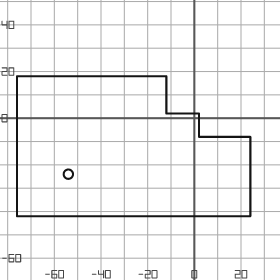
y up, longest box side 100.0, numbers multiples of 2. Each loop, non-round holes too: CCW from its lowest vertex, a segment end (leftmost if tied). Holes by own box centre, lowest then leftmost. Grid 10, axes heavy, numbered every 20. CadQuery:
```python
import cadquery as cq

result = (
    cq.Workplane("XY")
    .moveTo(-76.0, -42.0)
    .lineTo(24.0, -42.0)
    .lineTo(24.0, -8.0)
    .lineTo(2.0, -8.0)
    .lineTo(2.0, 2.0)
    .lineTo(-12.0, 2.0)
    .lineTo(-12.0, 18.0)
    .lineTo(-76.0, 18.0)
    .close()
    .moveTo(-54.0, -24.0)
    .circle(2.0)
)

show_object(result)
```